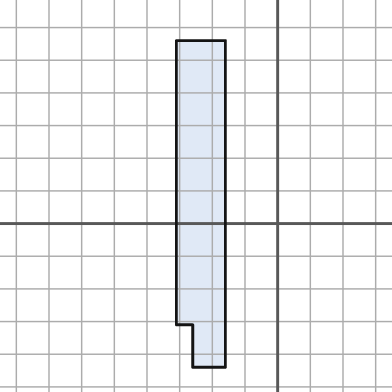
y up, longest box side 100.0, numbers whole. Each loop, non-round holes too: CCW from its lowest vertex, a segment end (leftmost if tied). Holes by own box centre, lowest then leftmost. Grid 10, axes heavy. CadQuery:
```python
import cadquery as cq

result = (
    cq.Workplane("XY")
    .moveTo(-26.0, -44.0)
    .lineTo(-16.0, -44.0)
    .lineTo(-16.0, 56.0)
    .lineTo(-31.0, 56.0)
    .lineTo(-31.0, -31.0)
    .lineTo(-26.0, -31.0)
    .close()
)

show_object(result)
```